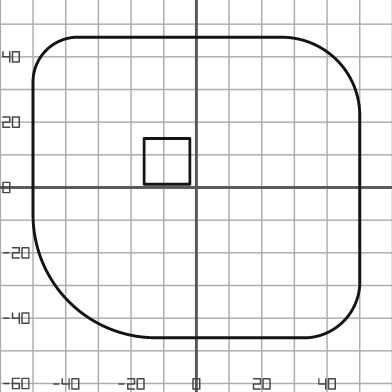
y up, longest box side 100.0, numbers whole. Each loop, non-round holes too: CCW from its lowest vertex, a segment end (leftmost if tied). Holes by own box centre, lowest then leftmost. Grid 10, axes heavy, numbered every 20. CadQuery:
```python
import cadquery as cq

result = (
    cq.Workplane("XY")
    .moveTo(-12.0, -46.0)
    .lineTo(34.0, -46.0)
    .threePointArc((45.0, -41.0), (50.0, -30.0))
    .lineTo(50.0, 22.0)
    .threePointArc((43.0, 39.0), (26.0, 46.0))
    .lineTo(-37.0, 46.0)
    .threePointArc((-46.0, 42.0), (-50.0, 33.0))
    .lineTo(-50.0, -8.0)
    .threePointArc((-39.0, -35.0), (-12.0, -46.0))
    .close()
    .moveTo(-16.0, 1.0)
    .lineTo(-2.0, 1.0)
    .lineTo(-2.0, 15.0)
    .lineTo(-16.0, 15.0)
    .close()
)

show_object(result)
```